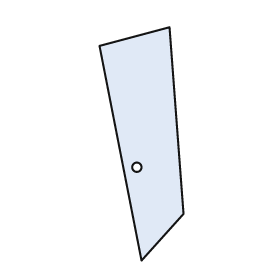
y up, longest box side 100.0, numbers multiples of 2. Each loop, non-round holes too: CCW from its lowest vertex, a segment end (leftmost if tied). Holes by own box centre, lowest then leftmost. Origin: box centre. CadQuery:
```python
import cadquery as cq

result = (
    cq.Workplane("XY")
    .moveTo(0.0, -50.0)
    .lineTo(18.0, -30.0)
    .lineTo(12.0, 50.0)
    .lineTo(-18.0, 42.0)
    .close()
    .moveTo(-2.0, -10.0)
    .circle(2.0)
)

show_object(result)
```